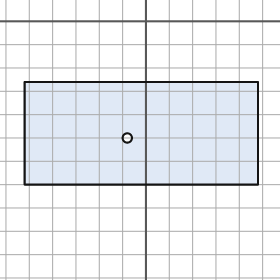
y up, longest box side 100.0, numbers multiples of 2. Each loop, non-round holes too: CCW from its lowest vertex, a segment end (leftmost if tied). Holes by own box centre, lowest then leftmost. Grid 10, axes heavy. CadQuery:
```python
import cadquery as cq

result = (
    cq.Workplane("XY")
    .moveTo(-52.0, -70.0)
    .lineTo(48.0, -70.0)
    .lineTo(48.0, -26.0)
    .lineTo(-52.0, -26.0)
    .close()
    .moveTo(-8.0, -50.0)
    .circle(2.0)
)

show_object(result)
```